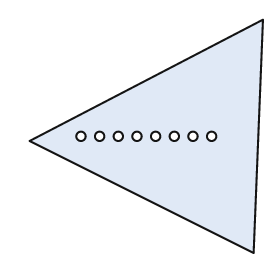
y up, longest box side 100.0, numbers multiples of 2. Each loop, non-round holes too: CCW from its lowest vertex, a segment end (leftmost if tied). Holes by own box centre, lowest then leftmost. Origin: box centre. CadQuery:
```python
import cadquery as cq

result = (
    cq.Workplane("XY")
    .moveTo(46.0, -50.0)
    .lineTo(50.0, 50.0)
    .lineTo(-50.0, -2.0)
    .close()
    .moveTo(-28.0, 0.0)
    .circle(2.0)
    .moveTo(-20.0, 0.0)
    .circle(2.0)
    .moveTo(-12.0, 0.0)
    .circle(2.0)
    .moveTo(-4.0, 0.0)
    .circle(2.0)
    .moveTo(4.0, 0.0)
    .circle(2.0)
    .moveTo(12.0, 0.0)
    .circle(2.0)
    .moveTo(20.0, 0.0)
    .circle(2.0)
    .moveTo(28.0, 0.0)
    .circle(2.0)
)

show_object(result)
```